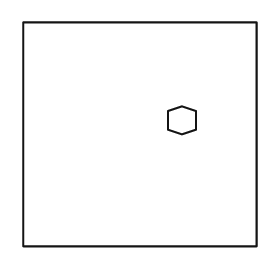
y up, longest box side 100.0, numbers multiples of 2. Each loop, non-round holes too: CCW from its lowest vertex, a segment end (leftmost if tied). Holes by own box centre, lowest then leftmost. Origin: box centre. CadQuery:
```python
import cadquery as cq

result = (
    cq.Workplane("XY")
    .moveTo(-50.0, -48.0)
    .lineTo(50.0, -48.0)
    .lineTo(50.0, 48.0)
    .lineTo(-50.0, 48.0)
    .close()
    .moveTo(18.0, 0.0)
    .lineTo(24.0, 2.0)
    .lineTo(24.0, 10.0)
    .lineTo(18.0, 12.0)
    .lineTo(12.0, 10.0)
    .lineTo(12.0, 2.0)
    .close()
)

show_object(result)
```